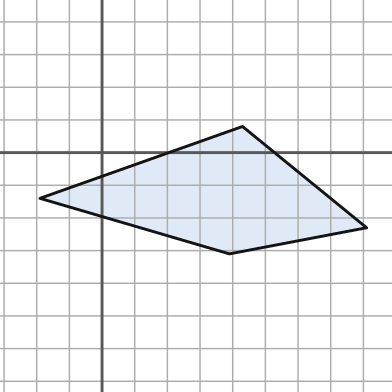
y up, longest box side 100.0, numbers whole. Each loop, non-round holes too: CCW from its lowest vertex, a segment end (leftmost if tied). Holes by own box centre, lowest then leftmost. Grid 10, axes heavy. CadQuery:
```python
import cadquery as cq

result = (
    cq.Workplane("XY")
    .moveTo(39.0, -31.0)
    .lineTo(81.0, -23.0)
    .lineTo(43.0, 8.0)
    .lineTo(-19.0, -14.0)
    .close()
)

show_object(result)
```